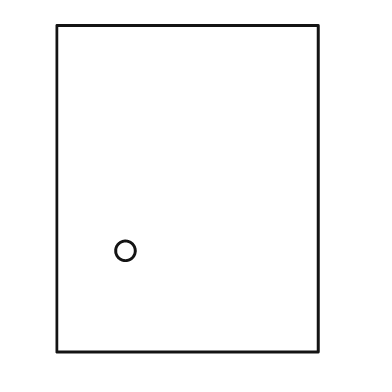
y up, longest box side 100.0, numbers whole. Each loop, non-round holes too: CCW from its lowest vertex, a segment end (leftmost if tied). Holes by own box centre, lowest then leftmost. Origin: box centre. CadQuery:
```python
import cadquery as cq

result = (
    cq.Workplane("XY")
    .moveTo(-40.0, -50.0)
    .lineTo(40.0, -50.0)
    .lineTo(40.0, 50.0)
    .lineTo(-40.0, 50.0)
    .close()
    .moveTo(-19.0, -19.0)
    .circle(3.0)
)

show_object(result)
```